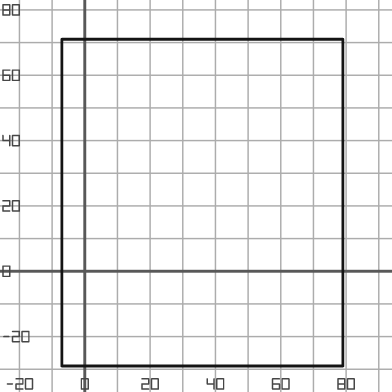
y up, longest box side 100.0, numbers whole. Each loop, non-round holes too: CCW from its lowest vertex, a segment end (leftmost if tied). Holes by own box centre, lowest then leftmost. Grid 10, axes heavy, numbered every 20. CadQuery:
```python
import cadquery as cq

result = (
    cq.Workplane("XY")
    .moveTo(-7.0, -29.0)
    .lineTo(79.0, -29.0)
    .lineTo(79.0, 71.0)
    .lineTo(-7.0, 71.0)
    .close()
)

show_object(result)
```